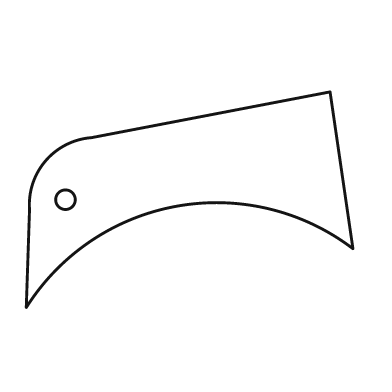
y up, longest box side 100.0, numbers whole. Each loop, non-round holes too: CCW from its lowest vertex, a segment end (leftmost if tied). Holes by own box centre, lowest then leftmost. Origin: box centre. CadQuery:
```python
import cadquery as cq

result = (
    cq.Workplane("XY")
    .moveTo(-50.0, -33.0)
    .threePointArc((-4.0, -2.0), (50.0, -15.0))
    .lineTo(43.0, 33.0)
    .lineTo(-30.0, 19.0)
    .threePointArc((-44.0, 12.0), (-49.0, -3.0))
    .close()
    .moveTo(-38.0, 0.0)
    .circle(3.0)
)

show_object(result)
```